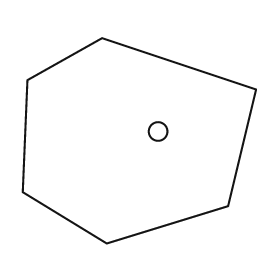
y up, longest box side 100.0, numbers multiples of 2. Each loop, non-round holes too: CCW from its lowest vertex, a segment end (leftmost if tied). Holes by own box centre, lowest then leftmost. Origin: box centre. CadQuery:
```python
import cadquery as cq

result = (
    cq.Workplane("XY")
    .moveTo(-14.0, -44.0)
    .lineTo(38.0, -28.0)
    .lineTo(50.0, 22.0)
    .lineTo(-16.0, 44.0)
    .lineTo(-48.0, 26.0)
    .lineTo(-50.0, -22.0)
    .close()
    .moveTo(8.0, 4.0)
    .circle(4.0)
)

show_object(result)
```